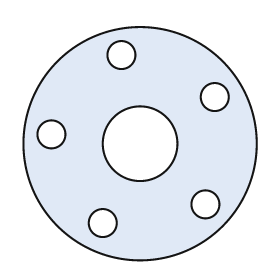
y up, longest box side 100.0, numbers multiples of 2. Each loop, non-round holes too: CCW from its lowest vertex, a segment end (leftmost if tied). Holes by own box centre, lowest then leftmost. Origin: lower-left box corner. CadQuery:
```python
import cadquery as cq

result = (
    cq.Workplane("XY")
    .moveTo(50.0, 50.0)
    .circle(50.0)
    .moveTo(34.0, 16.0)
    .circle(6.0)
    .moveTo(78.0, 24.0)
    .circle(6.0)
    .moveTo(50.0, 50.0)
    .circle(16.0)
    .moveTo(12.0, 54.0)
    .circle(6.0)
    .moveTo(82.0, 70.0)
    .circle(6.0)
    .moveTo(42.0, 88.0)
    .circle(6.0)
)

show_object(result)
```